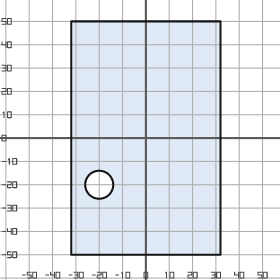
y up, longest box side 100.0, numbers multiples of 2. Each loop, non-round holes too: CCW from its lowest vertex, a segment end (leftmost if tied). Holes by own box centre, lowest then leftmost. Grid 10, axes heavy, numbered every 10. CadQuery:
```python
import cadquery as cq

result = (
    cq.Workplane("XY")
    .moveTo(-32.0, -50.0)
    .lineTo(32.0, -50.0)
    .lineTo(32.0, 50.0)
    .lineTo(-32.0, 50.0)
    .close()
    .moveTo(-20.0, -20.0)
    .circle(6.0)
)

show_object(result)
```